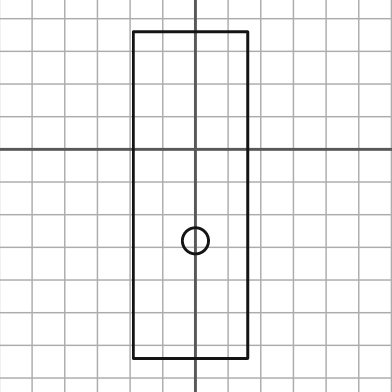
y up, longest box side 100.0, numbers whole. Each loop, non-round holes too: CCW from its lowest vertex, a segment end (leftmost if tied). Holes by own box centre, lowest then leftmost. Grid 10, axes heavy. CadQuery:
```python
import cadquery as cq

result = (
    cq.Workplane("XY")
    .moveTo(-19.0, -64.0)
    .lineTo(16.0, -64.0)
    .lineTo(16.0, 36.0)
    .lineTo(-19.0, 36.0)
    .close()
    .moveTo(0.0, -28.0)
    .circle(4.0)
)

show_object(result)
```